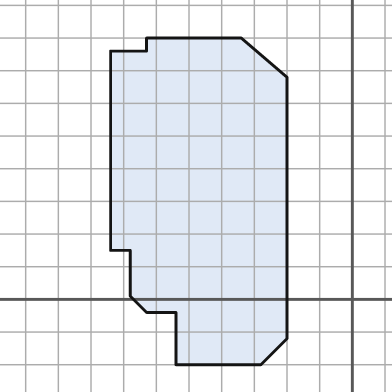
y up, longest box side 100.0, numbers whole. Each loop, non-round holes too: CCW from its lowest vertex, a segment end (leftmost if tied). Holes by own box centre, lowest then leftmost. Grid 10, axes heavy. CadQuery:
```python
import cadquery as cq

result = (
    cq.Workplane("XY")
    .moveTo(-54.0, -20.0)
    .lineTo(-28.0, -20.0)
    .lineTo(-20.0, -12.0)
    .lineTo(-20.0, 68.0)
    .lineTo(-34.0, 80.0)
    .lineTo(-63.0, 80.0)
    .lineTo(-63.0, 76.0)
    .lineTo(-74.0, 76.0)
    .lineTo(-74.0, 15.0)
    .lineTo(-68.0, 15.0)
    .lineTo(-68.0, 1.0)
    .lineTo(-63.0, -4.0)
    .lineTo(-54.0, -4.0)
    .close()
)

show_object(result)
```